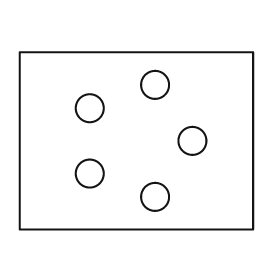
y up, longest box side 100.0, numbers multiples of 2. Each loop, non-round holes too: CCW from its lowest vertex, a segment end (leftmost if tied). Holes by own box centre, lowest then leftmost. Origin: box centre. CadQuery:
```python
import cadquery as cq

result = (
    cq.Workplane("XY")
    .moveTo(-50.0, -38.0)
    .lineTo(50.0, -38.0)
    .lineTo(50.0, 38.0)
    .lineTo(-50.0, 38.0)
    .close()
    .moveTo(8.0, -24.0)
    .circle(6.0)
    .moveTo(-20.0, -14.0)
    .circle(6.0)
    .moveTo(24.0, 0.0)
    .circle(6.0)
    .moveTo(-20.0, 14.0)
    .circle(6.0)
    .moveTo(8.0, 24.0)
    .circle(6.0)
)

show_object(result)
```